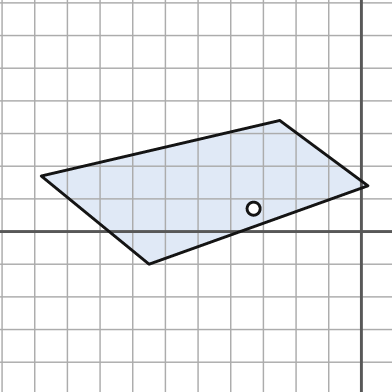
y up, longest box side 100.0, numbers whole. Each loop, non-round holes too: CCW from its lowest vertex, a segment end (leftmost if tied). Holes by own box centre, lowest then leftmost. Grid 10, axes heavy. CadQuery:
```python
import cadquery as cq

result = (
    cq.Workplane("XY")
    .moveTo(-65.0, -10.0)
    .lineTo(2.0, 14.0)
    .lineTo(-25.0, 34.0)
    .lineTo(-98.0, 17.0)
    .close()
    .moveTo(-33.0, 7.0)
    .circle(2.0)
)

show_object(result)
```